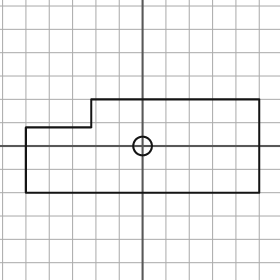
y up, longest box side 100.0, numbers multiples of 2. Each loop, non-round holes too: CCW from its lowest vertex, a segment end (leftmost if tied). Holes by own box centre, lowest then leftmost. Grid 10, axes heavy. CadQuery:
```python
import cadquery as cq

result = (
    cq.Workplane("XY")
    .moveTo(-50.0, -20.0)
    .lineTo(50.0, -20.0)
    .lineTo(50.0, 20.0)
    .lineTo(-22.0, 20.0)
    .lineTo(-22.0, 8.0)
    .lineTo(-50.0, 8.0)
    .close()
    .moveTo(0.0, 0.0)
    .circle(4.0)
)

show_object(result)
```